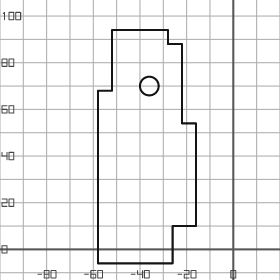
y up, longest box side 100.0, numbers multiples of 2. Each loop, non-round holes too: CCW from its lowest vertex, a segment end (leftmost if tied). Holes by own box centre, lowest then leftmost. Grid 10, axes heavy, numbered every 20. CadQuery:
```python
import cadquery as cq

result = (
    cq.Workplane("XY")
    .moveTo(-58.0, -6.0)
    .lineTo(-26.0, -6.0)
    .lineTo(-26.0, 10.0)
    .lineTo(-16.0, 10.0)
    .lineTo(-16.0, 54.0)
    .lineTo(-22.0, 54.0)
    .lineTo(-22.0, 88.0)
    .lineTo(-28.0, 88.0)
    .lineTo(-28.0, 94.0)
    .lineTo(-52.0, 94.0)
    .lineTo(-52.0, 68.0)
    .lineTo(-58.0, 68.0)
    .close()
    .moveTo(-36.0, 70.0)
    .circle(4.0)
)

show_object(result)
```